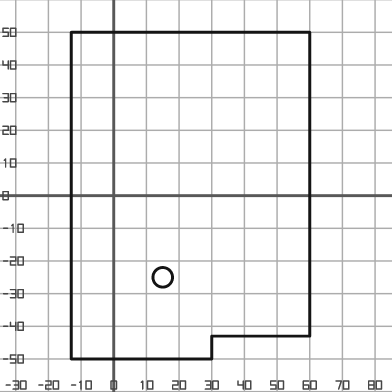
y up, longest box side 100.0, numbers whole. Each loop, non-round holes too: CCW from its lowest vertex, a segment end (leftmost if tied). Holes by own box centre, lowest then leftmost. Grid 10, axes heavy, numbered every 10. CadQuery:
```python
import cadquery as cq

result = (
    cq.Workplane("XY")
    .moveTo(-13.0, -50.0)
    .lineTo(30.0, -50.0)
    .lineTo(30.0, -43.0)
    .lineTo(60.0, -43.0)
    .lineTo(60.0, 50.0)
    .lineTo(-13.0, 50.0)
    .close()
    .moveTo(15.0, -25.0)
    .circle(3.0)
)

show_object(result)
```